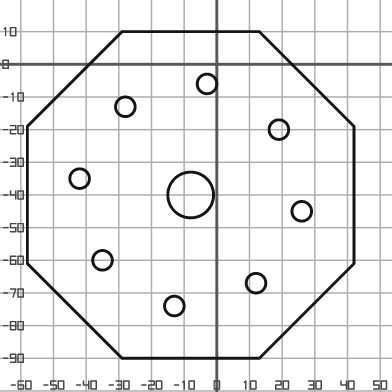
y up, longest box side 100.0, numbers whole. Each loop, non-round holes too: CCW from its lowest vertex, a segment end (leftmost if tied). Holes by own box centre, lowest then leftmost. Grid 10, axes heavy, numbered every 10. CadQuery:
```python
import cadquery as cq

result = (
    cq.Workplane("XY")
    .moveTo(-29.0, -90.0)
    .lineTo(13.0, -90.0)
    .lineTo(42.0, -61.0)
    .lineTo(42.0, -19.0)
    .lineTo(13.0, 10.0)
    .lineTo(-29.0, 10.0)
    .lineTo(-58.0, -19.0)
    .lineTo(-58.0, -61.0)
    .close()
    .moveTo(-13.0, -74.0)
    .circle(3.0)
    .moveTo(12.0, -67.0)
    .circle(3.0)
    .moveTo(-35.0, -60.0)
    .circle(3.0)
    .moveTo(26.0, -45.0)
    .circle(3.0)
    .moveTo(-8.0, -40.0)
    .circle(7.0)
    .moveTo(-42.0, -35.0)
    .circle(3.0)
    .moveTo(19.0, -20.0)
    .circle(3.0)
    .moveTo(-28.0, -13.0)
    .circle(3.0)
    .moveTo(-3.0, -6.0)
    .circle(3.0)
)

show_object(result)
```